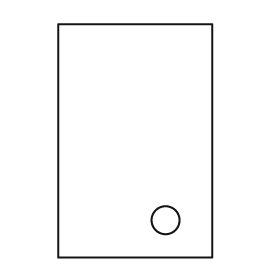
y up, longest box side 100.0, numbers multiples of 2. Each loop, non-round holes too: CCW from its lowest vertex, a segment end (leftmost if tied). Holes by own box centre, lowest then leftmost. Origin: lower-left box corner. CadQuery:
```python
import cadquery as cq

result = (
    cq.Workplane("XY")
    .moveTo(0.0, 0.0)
    .lineTo(66.0, 0.0)
    .lineTo(66.0, 100.0)
    .lineTo(0.0, 100.0)
    .close()
    .moveTo(46.0, 16.0)
    .circle(6.0)
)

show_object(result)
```